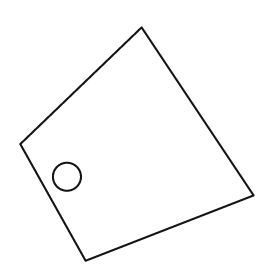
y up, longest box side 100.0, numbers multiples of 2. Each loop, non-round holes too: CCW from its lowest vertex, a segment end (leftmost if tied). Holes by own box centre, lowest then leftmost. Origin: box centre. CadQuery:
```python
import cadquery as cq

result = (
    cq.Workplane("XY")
    .moveTo(-22.0, -50.0)
    .lineTo(50.0, -22.0)
    .lineTo(2.0, 50.0)
    .lineTo(-50.0, 0.0)
    .close()
    .moveTo(-30.0, -14.0)
    .circle(6.0)
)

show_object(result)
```